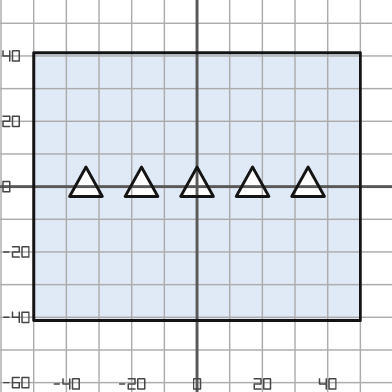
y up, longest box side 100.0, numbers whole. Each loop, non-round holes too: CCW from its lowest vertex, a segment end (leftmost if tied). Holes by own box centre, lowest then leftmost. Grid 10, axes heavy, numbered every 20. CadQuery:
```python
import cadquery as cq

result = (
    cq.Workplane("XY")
    .moveTo(-50.0, -41.0)
    .lineTo(50.0, -41.0)
    .lineTo(50.0, 41.0)
    .lineTo(-50.0, 41.0)
    .close()
    .moveTo(-39.0, -3.0)
    .lineTo(-29.0, -3.0)
    .lineTo(-34.0, 6.0)
    .close()
    .moveTo(-22.0, -3.0)
    .lineTo(-12.0, -3.0)
    .lineTo(-17.0, 6.0)
    .close()
    .moveTo(-5.0, -3.0)
    .lineTo(5.0, -3.0)
    .lineTo(0.0, 6.0)
    .close()
    .moveTo(12.0, -3.0)
    .lineTo(22.0, -3.0)
    .lineTo(17.0, 6.0)
    .close()
    .moveTo(29.0, -3.0)
    .lineTo(39.0, -3.0)
    .lineTo(34.0, 6.0)
    .close()
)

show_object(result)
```